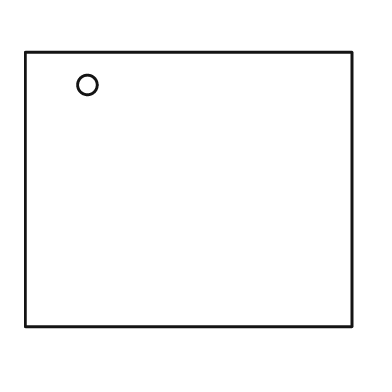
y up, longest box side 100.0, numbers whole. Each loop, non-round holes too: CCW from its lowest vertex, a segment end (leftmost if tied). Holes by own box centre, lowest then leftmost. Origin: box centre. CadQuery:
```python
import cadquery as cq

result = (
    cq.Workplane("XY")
    .moveTo(-50.0, -42.0)
    .lineTo(50.0, -42.0)
    .lineTo(50.0, 42.0)
    .lineTo(-50.0, 42.0)
    .close()
    .moveTo(-31.0, 32.0)
    .circle(3.0)
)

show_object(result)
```